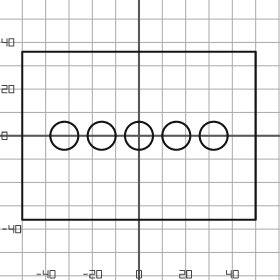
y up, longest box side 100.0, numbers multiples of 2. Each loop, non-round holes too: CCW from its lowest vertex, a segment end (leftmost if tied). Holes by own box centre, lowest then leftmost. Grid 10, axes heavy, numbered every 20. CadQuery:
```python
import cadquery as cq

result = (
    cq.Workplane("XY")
    .moveTo(-50.0, -36.0)
    .lineTo(50.0, -36.0)
    .lineTo(50.0, 36.0)
    .lineTo(-50.0, 36.0)
    .close()
    .moveTo(-32.0, 0.0)
    .circle(6.0)
    .moveTo(-16.0, 0.0)
    .circle(6.0)
    .moveTo(0.0, 0.0)
    .circle(6.0)
    .moveTo(16.0, 0.0)
    .circle(6.0)
    .moveTo(32.0, 0.0)
    .circle(6.0)
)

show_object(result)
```